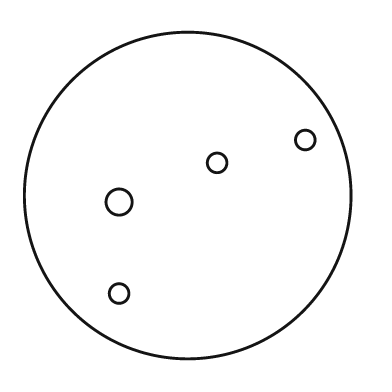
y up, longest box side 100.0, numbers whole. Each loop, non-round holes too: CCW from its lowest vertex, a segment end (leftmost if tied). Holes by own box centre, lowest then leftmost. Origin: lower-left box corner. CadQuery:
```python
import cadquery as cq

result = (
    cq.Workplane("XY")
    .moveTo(50.0, 50.0)
    .circle(50.0)
    .moveTo(29.0, 20.0)
    .circle(3.0)
    .moveTo(29.0, 48.0)
    .circle(4.0)
    .moveTo(59.0, 60.0)
    .circle(3.0)
    .moveTo(86.0, 67.0)
    .circle(3.0)
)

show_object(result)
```